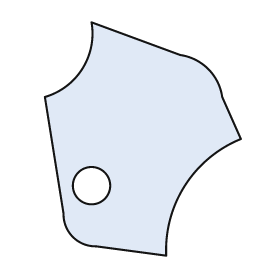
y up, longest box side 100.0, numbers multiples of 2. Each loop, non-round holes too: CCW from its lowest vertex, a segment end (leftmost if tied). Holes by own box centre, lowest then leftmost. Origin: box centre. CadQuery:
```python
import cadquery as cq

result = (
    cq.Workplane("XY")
    .moveTo(10.0, -50.0)
    .threePointArc((18.0, -20.0), (42.0, 0.0))
    .lineTo(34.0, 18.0)
    .threePointArc((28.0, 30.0), (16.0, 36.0))
    .lineTo(-22.0, 50.0)
    .threePointArc((-26.0, 30.0), (-42.0, 18.0))
    .lineTo(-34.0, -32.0)
    .threePointArc((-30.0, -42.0), (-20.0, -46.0))
    .close()
    .moveTo(-22.0, -20.0)
    .circle(8.0)
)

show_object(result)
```